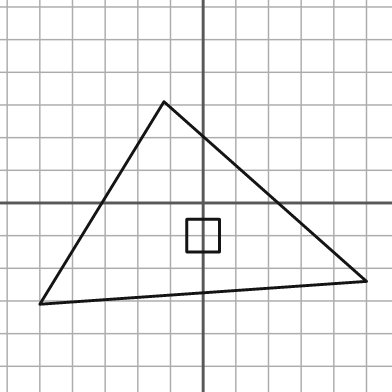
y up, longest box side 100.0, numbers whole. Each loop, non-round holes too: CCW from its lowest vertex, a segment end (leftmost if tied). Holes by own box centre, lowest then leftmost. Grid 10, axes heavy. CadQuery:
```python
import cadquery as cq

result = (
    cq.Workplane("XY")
    .moveTo(-50.0, -31.0)
    .lineTo(50.0, -24.0)
    .lineTo(-12.0, 31.0)
    .close()
    .moveTo(-5.0, -15.0)
    .lineTo(5.0, -15.0)
    .lineTo(5.0, -5.0)
    .lineTo(-5.0, -5.0)
    .close()
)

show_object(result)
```